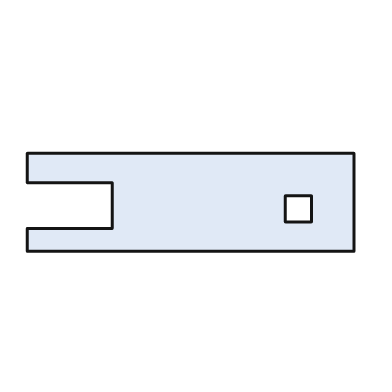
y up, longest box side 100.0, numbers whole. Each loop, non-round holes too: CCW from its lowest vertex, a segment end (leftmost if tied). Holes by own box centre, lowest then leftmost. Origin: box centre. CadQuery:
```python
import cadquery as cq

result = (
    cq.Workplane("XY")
    .moveTo(-50.0, -15.0)
    .lineTo(50.0, -15.0)
    .lineTo(50.0, 15.0)
    .lineTo(-50.0, 15.0)
    .lineTo(-50.0, 6.0)
    .lineTo(-24.0, 6.0)
    .lineTo(-24.0, -8.0)
    .lineTo(-50.0, -8.0)
    .close()
    .moveTo(29.0, -6.0)
    .lineTo(37.0, -6.0)
    .lineTo(37.0, 2.0)
    .lineTo(29.0, 2.0)
    .close()
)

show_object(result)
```